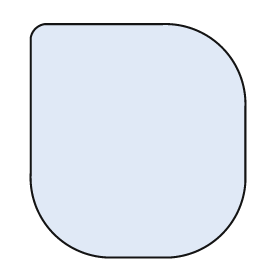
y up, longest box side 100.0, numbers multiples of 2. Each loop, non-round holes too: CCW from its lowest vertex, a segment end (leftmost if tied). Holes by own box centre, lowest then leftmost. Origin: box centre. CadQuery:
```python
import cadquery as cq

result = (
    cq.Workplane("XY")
    .moveTo(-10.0, -50.0)
    .lineTo(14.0, -50.0)
    .threePointArc((36.0, -40.0), (46.0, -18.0))
    .lineTo(46.0, 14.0)
    .threePointArc((36.0, 40.0), (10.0, 50.0))
    .lineTo(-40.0, 50.0)
    .threePointArc((-44.0, 48.0), (-46.0, 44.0))
    .lineTo(-46.0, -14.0)
    .threePointArc((-36.0, -40.0), (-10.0, -50.0))
    .close()
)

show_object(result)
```